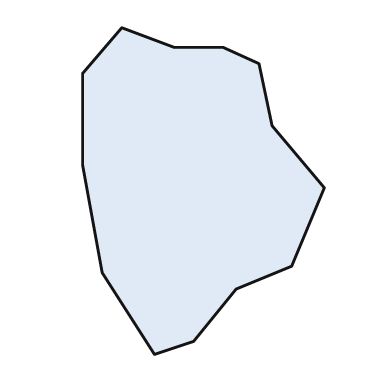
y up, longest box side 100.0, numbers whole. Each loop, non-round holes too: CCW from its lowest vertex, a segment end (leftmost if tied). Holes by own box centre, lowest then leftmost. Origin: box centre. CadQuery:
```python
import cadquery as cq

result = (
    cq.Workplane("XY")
    .moveTo(-15.0, -50.0)
    .lineTo(-3.0, -46.0)
    .lineTo(10.0, -30.0)
    .lineTo(27.0, -23.0)
    .lineTo(37.0, 1.0)
    .lineTo(21.0, 20.0)
    .lineTo(17.0, 39.0)
    .lineTo(6.0, 44.0)
    .lineTo(-9.0, 44.0)
    .lineTo(-25.0, 50.0)
    .lineTo(-37.0, 36.0)
    .lineTo(-37.0, 8.0)
    .lineTo(-31.0, -25.0)
    .close()
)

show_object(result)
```